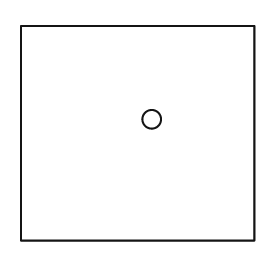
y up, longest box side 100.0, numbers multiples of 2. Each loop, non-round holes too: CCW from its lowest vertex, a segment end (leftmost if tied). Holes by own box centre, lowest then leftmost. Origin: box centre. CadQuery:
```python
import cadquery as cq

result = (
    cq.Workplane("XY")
    .moveTo(-50.0, -46.0)
    .lineTo(50.0, -46.0)
    .lineTo(50.0, 46.0)
    .lineTo(-50.0, 46.0)
    .close()
    .moveTo(6.0, 6.0)
    .circle(4.0)
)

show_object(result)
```